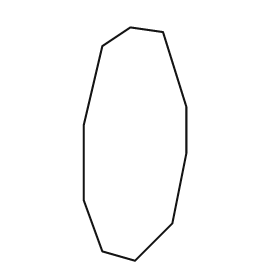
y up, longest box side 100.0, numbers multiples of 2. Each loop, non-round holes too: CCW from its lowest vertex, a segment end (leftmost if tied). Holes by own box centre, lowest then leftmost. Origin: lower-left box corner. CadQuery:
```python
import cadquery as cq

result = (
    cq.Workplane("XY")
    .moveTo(22.0, 0.0)
    .lineTo(38.0, 16.0)
    .lineTo(44.0, 46.0)
    .lineTo(44.0, 66.0)
    .lineTo(34.0, 98.0)
    .lineTo(20.0, 100.0)
    .lineTo(8.0, 92.0)
    .lineTo(0.0, 58.0)
    .lineTo(0.0, 26.0)
    .lineTo(8.0, 4.0)
    .close()
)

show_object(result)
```